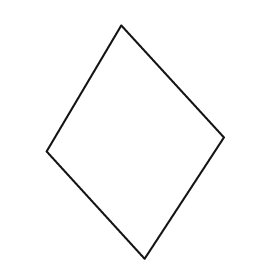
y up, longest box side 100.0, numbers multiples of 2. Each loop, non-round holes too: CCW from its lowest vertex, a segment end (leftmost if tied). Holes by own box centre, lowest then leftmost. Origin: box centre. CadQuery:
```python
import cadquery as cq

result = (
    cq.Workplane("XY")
    .moveTo(4.0, -50.0)
    .lineTo(38.0, 2.0)
    .lineTo(-6.0, 50.0)
    .lineTo(-38.0, -4.0)
    .close()
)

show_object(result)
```